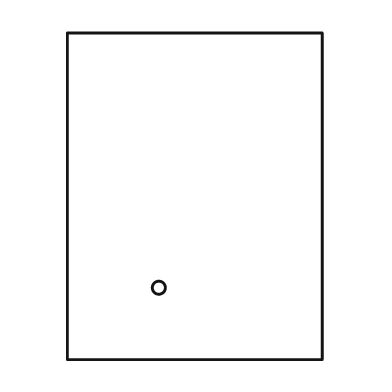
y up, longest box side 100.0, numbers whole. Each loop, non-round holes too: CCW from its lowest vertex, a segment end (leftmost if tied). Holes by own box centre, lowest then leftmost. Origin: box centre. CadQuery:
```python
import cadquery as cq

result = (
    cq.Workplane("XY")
    .moveTo(-39.0, -50.0)
    .lineTo(39.0, -50.0)
    .lineTo(39.0, 50.0)
    .lineTo(-39.0, 50.0)
    .close()
    .moveTo(-11.0, -28.0)
    .circle(2.0)
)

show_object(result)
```